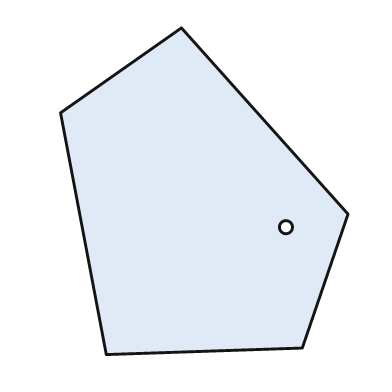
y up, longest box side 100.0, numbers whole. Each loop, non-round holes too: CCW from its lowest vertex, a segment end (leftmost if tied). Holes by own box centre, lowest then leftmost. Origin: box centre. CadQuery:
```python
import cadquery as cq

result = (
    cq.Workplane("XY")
    .moveTo(-30.0, -50.0)
    .lineTo(30.0, -48.0)
    .lineTo(44.0, -7.0)
    .lineTo(-7.0, 50.0)
    .lineTo(-44.0, 24.0)
    .close()
    .moveTo(25.0, -11.0)
    .circle(2.0)
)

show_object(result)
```